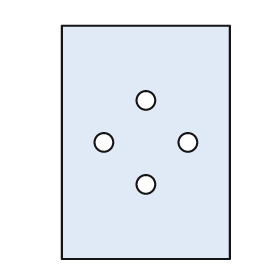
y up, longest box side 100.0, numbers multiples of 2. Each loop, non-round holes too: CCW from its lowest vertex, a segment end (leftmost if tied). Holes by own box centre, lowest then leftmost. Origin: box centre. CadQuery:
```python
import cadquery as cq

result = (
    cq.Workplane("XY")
    .moveTo(-36.0, -50.0)
    .lineTo(36.0, -50.0)
    .lineTo(36.0, 50.0)
    .lineTo(-36.0, 50.0)
    .close()
    .moveTo(0.0, -18.0)
    .circle(4.0)
    .moveTo(-18.0, 0.0)
    .circle(4.0)
    .moveTo(18.0, 0.0)
    .circle(4.0)
    .moveTo(0.0, 18.0)
    .circle(4.0)
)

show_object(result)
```